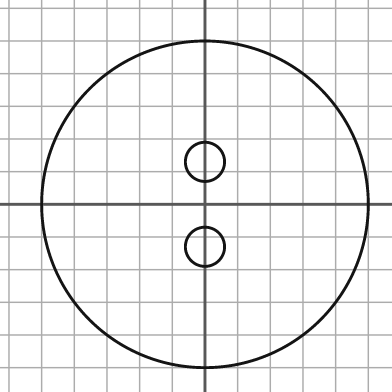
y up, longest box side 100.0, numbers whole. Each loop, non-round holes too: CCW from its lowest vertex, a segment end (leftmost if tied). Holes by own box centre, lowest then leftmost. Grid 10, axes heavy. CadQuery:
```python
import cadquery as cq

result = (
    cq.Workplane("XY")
    .moveTo(0.0, 0.0)
    .circle(50.0)
    .moveTo(0.0, -13.0)
    .circle(6.0)
    .moveTo(0.0, 13.0)
    .circle(6.0)
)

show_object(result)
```